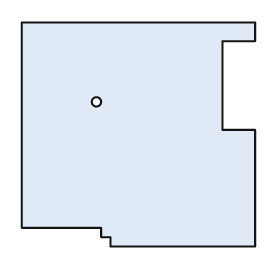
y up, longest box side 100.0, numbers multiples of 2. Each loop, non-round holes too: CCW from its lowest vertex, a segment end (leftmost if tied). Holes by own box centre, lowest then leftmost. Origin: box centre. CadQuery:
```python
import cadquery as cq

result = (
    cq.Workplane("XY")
    .moveTo(-12.0, -48.0)
    .lineTo(50.0, -48.0)
    .lineTo(50.0, 2.0)
    .lineTo(36.0, 2.0)
    .lineTo(36.0, 40.0)
    .lineTo(50.0, 40.0)
    .lineTo(50.0, 48.0)
    .lineTo(-50.0, 48.0)
    .lineTo(-50.0, -40.0)
    .lineTo(-16.0, -40.0)
    .lineTo(-16.0, -44.0)
    .lineTo(-12.0, -44.0)
    .close()
    .moveTo(-18.0, 14.0)
    .circle(2.0)
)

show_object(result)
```